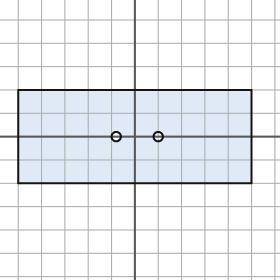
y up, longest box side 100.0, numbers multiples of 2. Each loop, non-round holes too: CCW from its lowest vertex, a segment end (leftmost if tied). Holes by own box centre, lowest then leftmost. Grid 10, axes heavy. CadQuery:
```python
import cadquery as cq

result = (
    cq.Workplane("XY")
    .moveTo(-50.0, -20.0)
    .lineTo(50.0, -20.0)
    .lineTo(50.0, 20.0)
    .lineTo(-50.0, 20.0)
    .close()
    .moveTo(-8.0, 0.0)
    .circle(2.0)
    .moveTo(10.0, 0.0)
    .circle(2.0)
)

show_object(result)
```